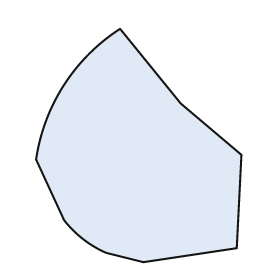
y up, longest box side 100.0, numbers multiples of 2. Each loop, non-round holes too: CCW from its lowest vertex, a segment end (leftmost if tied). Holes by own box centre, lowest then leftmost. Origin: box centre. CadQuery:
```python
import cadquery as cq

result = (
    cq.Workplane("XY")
    .moveTo(2.0, -50.0)
    .lineTo(42.0, -44.0)
    .lineTo(44.0, -4.0)
    .lineTo(18.0, 18.0)
    .lineTo(-8.0, 50.0)
    .threePointArc((-32.0, 26.0), (-44.0, -6.0))
    .lineTo(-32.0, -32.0)
    .threePointArc((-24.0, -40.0), (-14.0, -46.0))
    .close()
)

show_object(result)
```